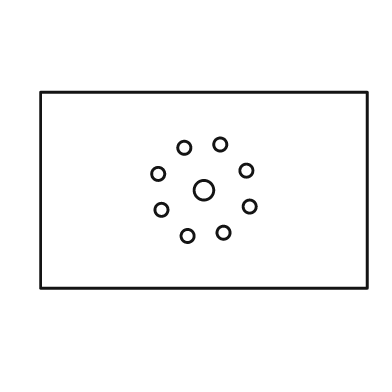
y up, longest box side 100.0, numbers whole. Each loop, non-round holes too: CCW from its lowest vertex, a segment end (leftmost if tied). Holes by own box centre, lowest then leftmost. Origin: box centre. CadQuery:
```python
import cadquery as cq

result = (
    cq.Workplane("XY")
    .moveTo(-50.0, -30.0)
    .lineTo(50.0, -30.0)
    .lineTo(50.0, 30.0)
    .lineTo(-50.0, 30.0)
    .close()
    .moveTo(-5.0, -14.0)
    .circle(2.0)
    .moveTo(6.0, -13.0)
    .circle(2.0)
    .moveTo(-13.0, -6.0)
    .circle(2.0)
    .moveTo(14.0, -5.0)
    .circle(2.0)
    .moveTo(0.0, 0.0)
    .circle(3.0)
    .moveTo(-14.0, 5.0)
    .circle(2.0)
    .moveTo(13.0, 6.0)
    .circle(2.0)
    .moveTo(-6.0, 13.0)
    .circle(2.0)
    .moveTo(5.0, 14.0)
    .circle(2.0)
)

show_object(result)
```